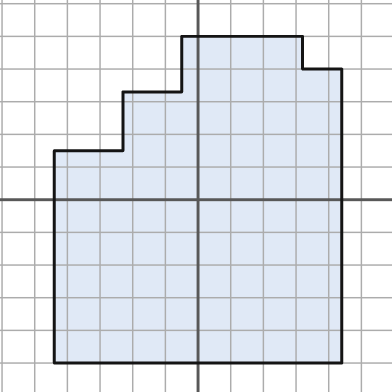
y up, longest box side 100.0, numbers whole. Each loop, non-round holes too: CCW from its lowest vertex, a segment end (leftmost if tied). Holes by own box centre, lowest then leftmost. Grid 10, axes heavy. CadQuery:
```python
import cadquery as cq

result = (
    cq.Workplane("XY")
    .moveTo(-44.0, -50.0)
    .lineTo(44.0, -50.0)
    .lineTo(44.0, 40.0)
    .lineTo(32.0, 40.0)
    .lineTo(32.0, 50.0)
    .lineTo(-5.0, 50.0)
    .lineTo(-5.0, 33.0)
    .lineTo(-23.0, 33.0)
    .lineTo(-23.0, 15.0)
    .lineTo(-44.0, 15.0)
    .close()
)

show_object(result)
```